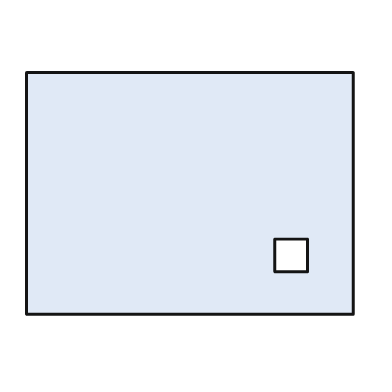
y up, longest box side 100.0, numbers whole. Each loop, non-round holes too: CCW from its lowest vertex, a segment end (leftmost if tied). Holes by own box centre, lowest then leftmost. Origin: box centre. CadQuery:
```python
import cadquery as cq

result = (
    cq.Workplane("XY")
    .moveTo(-50.0, -37.0)
    .lineTo(50.0, -37.0)
    .lineTo(50.0, 37.0)
    .lineTo(-50.0, 37.0)
    .close()
    .moveTo(26.0, -24.0)
    .lineTo(36.0, -24.0)
    .lineTo(36.0, -14.0)
    .lineTo(26.0, -14.0)
    .close()
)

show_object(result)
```